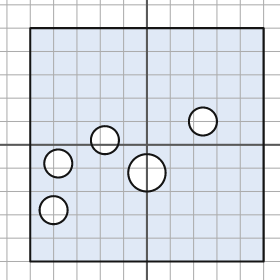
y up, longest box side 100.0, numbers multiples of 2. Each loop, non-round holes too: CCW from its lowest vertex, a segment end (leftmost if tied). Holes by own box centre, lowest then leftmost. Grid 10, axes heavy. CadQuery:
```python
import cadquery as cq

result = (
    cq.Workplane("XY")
    .moveTo(-50.0, -50.0)
    .lineTo(50.0, -50.0)
    .lineTo(50.0, 50.0)
    .lineTo(-50.0, 50.0)
    .close()
    .moveTo(-40.0, -28.0)
    .circle(6.0)
    .moveTo(0.0, -12.0)
    .circle(8.0)
    .moveTo(-38.0, -8.0)
    .circle(6.0)
    .moveTo(-18.0, 2.0)
    .circle(6.0)
    .moveTo(24.0, 10.0)
    .circle(6.0)
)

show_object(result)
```